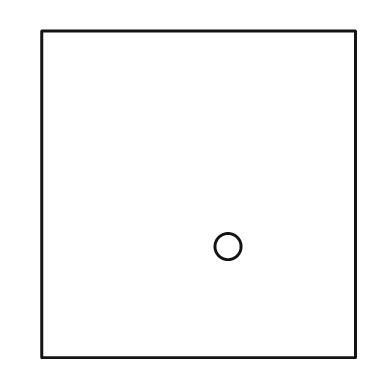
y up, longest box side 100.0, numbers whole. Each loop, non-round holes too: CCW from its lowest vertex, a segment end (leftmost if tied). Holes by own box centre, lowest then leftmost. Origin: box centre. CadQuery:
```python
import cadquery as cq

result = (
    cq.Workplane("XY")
    .moveTo(-48.0, -50.0)
    .lineTo(48.0, -50.0)
    .lineTo(48.0, 50.0)
    .lineTo(-48.0, 50.0)
    .close()
    .moveTo(9.0, -16.0)
    .circle(4.0)
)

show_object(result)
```